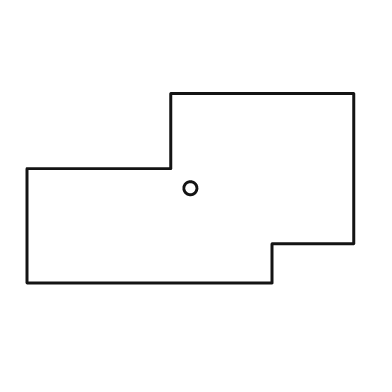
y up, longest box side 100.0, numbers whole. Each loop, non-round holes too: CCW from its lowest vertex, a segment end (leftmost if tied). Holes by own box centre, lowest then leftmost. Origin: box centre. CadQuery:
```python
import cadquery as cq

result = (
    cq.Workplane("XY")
    .moveTo(-50.0, -29.0)
    .lineTo(25.0, -29.0)
    .lineTo(25.0, -17.0)
    .lineTo(50.0, -17.0)
    .lineTo(50.0, 29.0)
    .lineTo(-6.0, 29.0)
    .lineTo(-6.0, 6.0)
    .lineTo(-50.0, 6.0)
    .close()
    .moveTo(0.0, 0.0)
    .circle(2.0)
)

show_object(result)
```